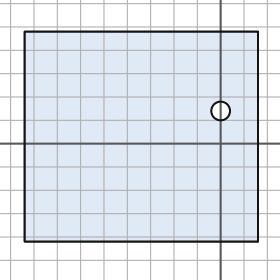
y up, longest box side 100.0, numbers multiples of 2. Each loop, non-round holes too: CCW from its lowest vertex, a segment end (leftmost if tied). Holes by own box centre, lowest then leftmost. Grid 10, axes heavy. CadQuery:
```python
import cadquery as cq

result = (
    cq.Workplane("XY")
    .moveTo(-84.0, -42.0)
    .lineTo(16.0, -42.0)
    .lineTo(16.0, 48.0)
    .lineTo(-84.0, 48.0)
    .close()
    .moveTo(0.0, 14.0)
    .circle(4.0)
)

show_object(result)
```